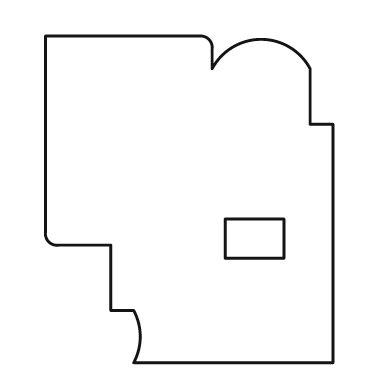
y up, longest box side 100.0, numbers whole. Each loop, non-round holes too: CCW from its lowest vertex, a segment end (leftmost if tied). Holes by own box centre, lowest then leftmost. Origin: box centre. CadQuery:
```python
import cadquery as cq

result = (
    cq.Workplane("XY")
    .moveTo(-17.0, -50.0)
    .lineTo(44.0, -50.0)
    .lineTo(44.0, 23.0)
    .lineTo(37.0, 23.0)
    .lineTo(37.0, 40.0)
    .threePointArc((22.0, 49.0), (7.0, 40.0))
    .lineTo(7.0, 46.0)
    .threePointArc((6.0, 49.0), (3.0, 50.0))
    .lineTo(-44.0, 50.0)
    .lineTo(-44.0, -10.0)
    .threePointArc((-43.0, -13.0), (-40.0, -14.0))
    .lineTo(-24.0, -14.0)
    .lineTo(-24.0, -34.0)
    .lineTo(-17.0, -34.0)
    .threePointArc((-15.0, -42.0), (-17.0, -50.0))
    .close()
    .moveTo(11.0, -18.0)
    .lineTo(29.0, -18.0)
    .lineTo(29.0, -6.0)
    .lineTo(11.0, -6.0)
    .close()
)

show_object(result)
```